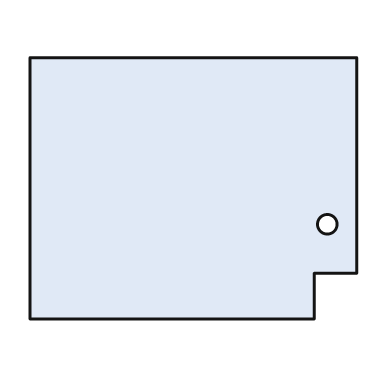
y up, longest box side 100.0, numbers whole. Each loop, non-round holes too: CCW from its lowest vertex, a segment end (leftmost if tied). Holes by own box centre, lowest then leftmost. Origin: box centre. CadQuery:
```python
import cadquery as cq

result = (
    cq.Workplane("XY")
    .moveTo(-50.0, -40.0)
    .lineTo(37.0, -40.0)
    .lineTo(37.0, -26.0)
    .lineTo(50.0, -26.0)
    .lineTo(50.0, 40.0)
    .lineTo(-50.0, 40.0)
    .close()
    .moveTo(41.0, -11.0)
    .circle(3.0)
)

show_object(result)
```